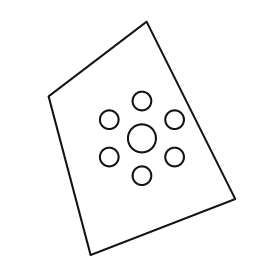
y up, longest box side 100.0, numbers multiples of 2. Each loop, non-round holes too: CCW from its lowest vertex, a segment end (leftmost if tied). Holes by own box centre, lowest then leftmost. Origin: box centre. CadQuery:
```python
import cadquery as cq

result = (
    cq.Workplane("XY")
    .moveTo(-22.0, -50.0)
    .lineTo(40.0, -26.0)
    .lineTo(2.0, 50.0)
    .lineTo(-40.0, 18.0)
    .close()
    .moveTo(0.0, -16.0)
    .circle(4.0)
    .moveTo(-14.0, -8.0)
    .circle(4.0)
    .moveTo(14.0, -8.0)
    .circle(4.0)
    .moveTo(0.0, 0.0)
    .circle(6.0)
    .moveTo(-14.0, 8.0)
    .circle(4.0)
    .moveTo(14.0, 8.0)
    .circle(4.0)
    .moveTo(0.0, 16.0)
    .circle(4.0)
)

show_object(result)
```